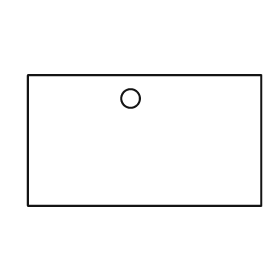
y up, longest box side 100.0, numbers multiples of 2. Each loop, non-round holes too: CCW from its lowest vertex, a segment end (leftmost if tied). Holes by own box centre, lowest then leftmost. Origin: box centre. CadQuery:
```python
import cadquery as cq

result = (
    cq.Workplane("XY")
    .moveTo(-50.0, -28.0)
    .lineTo(50.0, -28.0)
    .lineTo(50.0, 28.0)
    .lineTo(-50.0, 28.0)
    .close()
    .moveTo(-6.0, 18.0)
    .circle(4.0)
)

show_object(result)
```